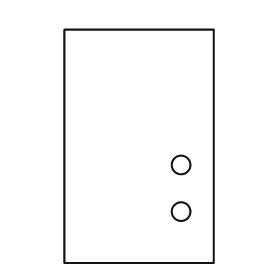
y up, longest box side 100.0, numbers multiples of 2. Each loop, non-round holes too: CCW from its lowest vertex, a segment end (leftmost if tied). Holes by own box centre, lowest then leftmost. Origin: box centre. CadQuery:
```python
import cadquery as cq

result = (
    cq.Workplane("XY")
    .moveTo(-32.0, -50.0)
    .lineTo(32.0, -50.0)
    .lineTo(32.0, 50.0)
    .lineTo(-32.0, 50.0)
    .close()
    .moveTo(18.0, -28.0)
    .circle(4.0)
    .moveTo(18.0, -8.0)
    .circle(4.0)
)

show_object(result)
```